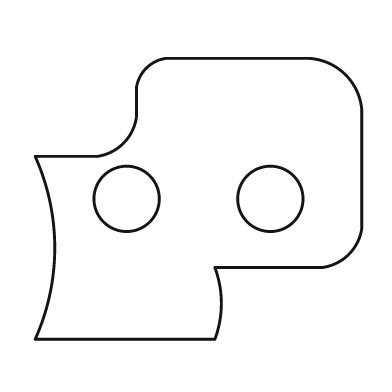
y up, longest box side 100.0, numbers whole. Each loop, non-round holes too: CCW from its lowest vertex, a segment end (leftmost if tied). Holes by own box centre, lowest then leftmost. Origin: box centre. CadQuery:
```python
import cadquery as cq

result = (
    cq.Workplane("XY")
    .moveTo(-50.0, -43.0)
    .lineTo(5.0, -43.0)
    .threePointArc((7.0, -32.0), (5.0, -21.0))
    .lineTo(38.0, -21.0)
    .threePointArc((46.0, -17.0), (50.0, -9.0))
    .lineTo(50.0, 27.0)
    .threePointArc((45.0, 38.0), (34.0, 43.0))
    .lineTo(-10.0, 43.0)
    .threePointArc((-16.0, 40.0), (-19.0, 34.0))
    .lineTo(-19.0, 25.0)
    .threePointArc((-23.0, 17.0), (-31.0, 13.0))
    .lineTo(-50.0, 13.0)
    .threePointArc((-44.0, -15.0), (-50.0, -43.0))
    .close()
    .moveTo(-22.0, 0.0)
    .circle(10.0)
    .moveTo(22.0, 0.0)
    .circle(10.0)
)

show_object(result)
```